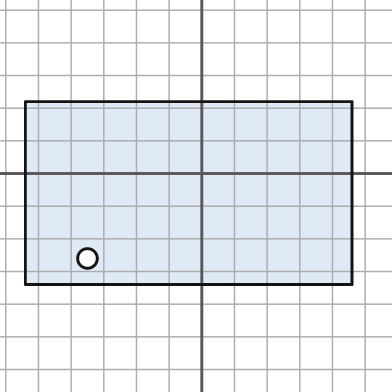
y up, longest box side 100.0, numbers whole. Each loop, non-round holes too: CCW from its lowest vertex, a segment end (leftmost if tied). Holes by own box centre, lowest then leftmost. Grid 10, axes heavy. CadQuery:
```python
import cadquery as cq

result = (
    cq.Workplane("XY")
    .moveTo(-54.0, -34.0)
    .lineTo(46.0, -34.0)
    .lineTo(46.0, 22.0)
    .lineTo(-54.0, 22.0)
    .close()
    .moveTo(-35.0, -26.0)
    .circle(3.0)
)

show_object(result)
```